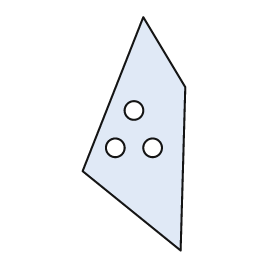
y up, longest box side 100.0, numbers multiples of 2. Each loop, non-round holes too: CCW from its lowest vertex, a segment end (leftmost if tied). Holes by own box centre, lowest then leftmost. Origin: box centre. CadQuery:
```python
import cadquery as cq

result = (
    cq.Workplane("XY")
    .moveTo(20.0, -50.0)
    .lineTo(22.0, 20.0)
    .lineTo(4.0, 50.0)
    .lineTo(-22.0, -16.0)
    .close()
    .moveTo(-8.0, -6.0)
    .circle(4.0)
    .moveTo(8.0, -6.0)
    .circle(4.0)
    .moveTo(0.0, 10.0)
    .circle(4.0)
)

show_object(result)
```